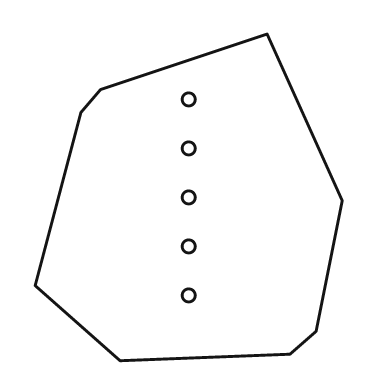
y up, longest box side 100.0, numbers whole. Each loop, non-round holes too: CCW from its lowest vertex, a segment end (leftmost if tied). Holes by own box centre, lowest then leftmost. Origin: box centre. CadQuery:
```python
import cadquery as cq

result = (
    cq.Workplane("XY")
    .moveTo(-21.0, -50.0)
    .lineTo(31.0, -48.0)
    .lineTo(39.0, -41.0)
    .lineTo(47.0, -1.0)
    .lineTo(24.0, 50.0)
    .lineTo(-27.0, 33.0)
    .lineTo(-33.0, 26.0)
    .lineTo(-47.0, -27.0)
    .close()
    .moveTo(0.0, -30.0)
    .circle(2.0)
    .moveTo(0.0, -15.0)
    .circle(2.0)
    .moveTo(0.0, 0.0)
    .circle(2.0)
    .moveTo(0.0, 15.0)
    .circle(2.0)
    .moveTo(0.0, 30.0)
    .circle(2.0)
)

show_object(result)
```